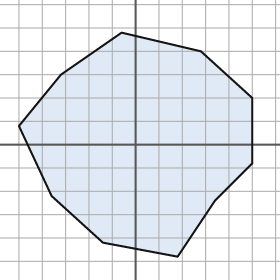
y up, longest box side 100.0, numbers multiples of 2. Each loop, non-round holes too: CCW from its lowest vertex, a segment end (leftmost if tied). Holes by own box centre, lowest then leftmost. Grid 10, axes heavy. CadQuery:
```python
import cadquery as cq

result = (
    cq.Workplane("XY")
    .moveTo(18.0, -48.0)
    .lineTo(34.0, -24.0)
    .lineTo(50.0, -8.0)
    .lineTo(50.0, 20.0)
    .lineTo(28.0, 40.0)
    .lineTo(-6.0, 48.0)
    .lineTo(-32.0, 30.0)
    .lineTo(-50.0, 8.0)
    .lineTo(-36.0, -22.0)
    .lineTo(-14.0, -42.0)
    .close()
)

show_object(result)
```